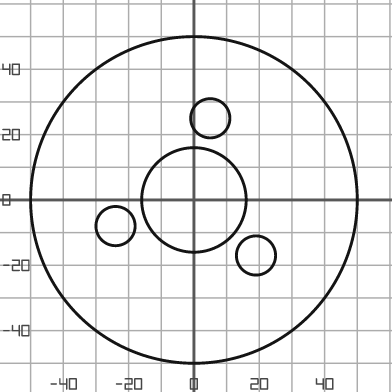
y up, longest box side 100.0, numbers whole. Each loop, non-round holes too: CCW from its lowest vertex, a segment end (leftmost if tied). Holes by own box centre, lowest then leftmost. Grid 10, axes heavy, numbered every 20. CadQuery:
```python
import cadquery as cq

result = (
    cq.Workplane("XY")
    .moveTo(0.0, 0.0)
    .circle(50.0)
    .moveTo(19.0, -17.0)
    .circle(6.0)
    .moveTo(-24.0, -8.0)
    .circle(6.0)
    .moveTo(0.0, 0.0)
    .circle(16.0)
    .moveTo(5.0, 25.0)
    .circle(6.0)
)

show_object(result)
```